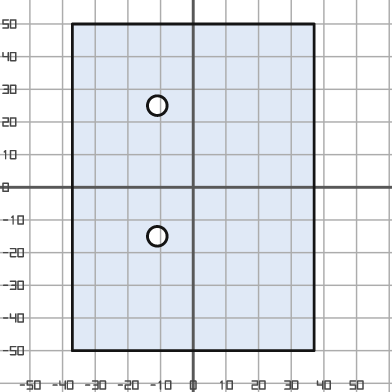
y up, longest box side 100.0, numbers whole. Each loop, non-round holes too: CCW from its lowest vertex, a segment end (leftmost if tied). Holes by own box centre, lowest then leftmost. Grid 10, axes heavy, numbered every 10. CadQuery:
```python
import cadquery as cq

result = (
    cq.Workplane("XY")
    .moveTo(-37.0, -50.0)
    .lineTo(37.0, -50.0)
    .lineTo(37.0, 50.0)
    .lineTo(-37.0, 50.0)
    .close()
    .moveTo(-11.0, -15.0)
    .circle(3.0)
    .moveTo(-11.0, 25.0)
    .circle(3.0)
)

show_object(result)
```